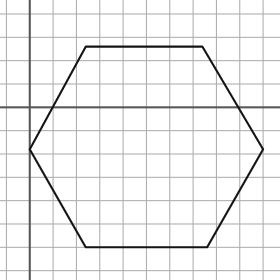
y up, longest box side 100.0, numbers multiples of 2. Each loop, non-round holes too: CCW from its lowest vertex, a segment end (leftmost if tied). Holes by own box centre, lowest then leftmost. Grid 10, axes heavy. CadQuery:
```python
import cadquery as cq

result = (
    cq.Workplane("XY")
    .moveTo(24.0, -60.0)
    .lineTo(76.0, -60.0)
    .lineTo(100.0, -18.0)
    .lineTo(74.0, 26.0)
    .lineTo(24.0, 26.0)
    .lineTo(0.0, -18.0)
    .close()
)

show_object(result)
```